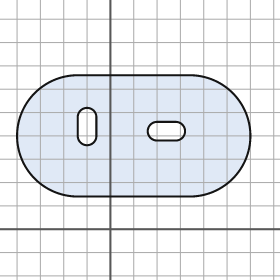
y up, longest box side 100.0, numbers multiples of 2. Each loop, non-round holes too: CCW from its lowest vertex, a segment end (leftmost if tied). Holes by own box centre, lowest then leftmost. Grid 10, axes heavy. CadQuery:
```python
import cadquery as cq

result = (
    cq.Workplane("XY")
    .moveTo(-14.0, 14.0)
    .lineTo(34.0, 14.0)
    .threePointArc((60.0, 40.0), (34.0, 66.0))
    .lineTo(-14.0, 66.0)
    .threePointArc((-40.0, 40.0), (-14.0, 14.0))
    .close()
    .moveTo(20.0, 38.0)
    .lineTo(28.0, 38.0)
    .threePointArc((32.0, 42.0), (28.0, 46.0))
    .lineTo(20.0, 46.0)
    .threePointArc((16.0, 42.0), (20.0, 38.0))
    .close()
    .moveTo(-14.0, 40.0)
    .threePointArc((-10.0, 36.0), (-6.0, 40.0))
    .lineTo(-6.0, 48.0)
    .threePointArc((-10.0, 52.0), (-14.0, 48.0))
    .close()
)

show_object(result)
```